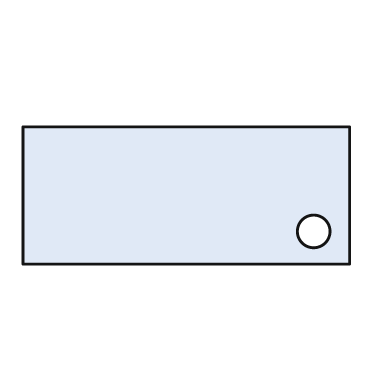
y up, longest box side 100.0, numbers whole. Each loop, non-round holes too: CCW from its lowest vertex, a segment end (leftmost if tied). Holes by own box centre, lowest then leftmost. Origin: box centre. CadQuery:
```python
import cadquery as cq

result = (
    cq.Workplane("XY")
    .moveTo(-50.0, -21.0)
    .lineTo(50.0, -21.0)
    .lineTo(50.0, 21.0)
    .lineTo(-50.0, 21.0)
    .close()
    .moveTo(39.0, -11.0)
    .circle(5.0)
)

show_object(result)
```